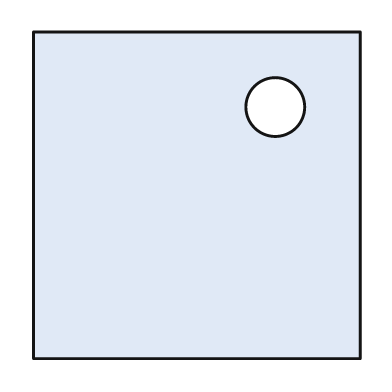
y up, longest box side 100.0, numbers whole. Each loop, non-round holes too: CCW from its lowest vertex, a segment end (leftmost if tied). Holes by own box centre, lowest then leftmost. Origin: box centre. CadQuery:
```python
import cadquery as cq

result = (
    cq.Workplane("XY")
    .moveTo(-50.0, -50.0)
    .lineTo(50.0, -50.0)
    .lineTo(50.0, 50.0)
    .lineTo(-50.0, 50.0)
    .close()
    .moveTo(24.0, 27.0)
    .circle(9.0)
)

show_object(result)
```